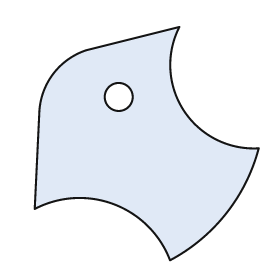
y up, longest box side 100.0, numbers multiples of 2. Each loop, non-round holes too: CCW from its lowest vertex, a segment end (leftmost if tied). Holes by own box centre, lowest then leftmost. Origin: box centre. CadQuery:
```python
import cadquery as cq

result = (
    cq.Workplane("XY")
    .moveTo(10.0, -50.0)
    .threePointArc((34.0, -30.0), (48.0, -2.0))
    .threePointArc((16.0, 14.0), (14.0, 50.0))
    .lineTo(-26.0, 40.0)
    .threePointArc((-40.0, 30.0), (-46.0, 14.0))
    .lineTo(-48.0, -28.0)
    .threePointArc((-14.0, -26.0), (10.0, -50.0))
    .close()
    .moveTo(-12.0, 20.0)
    .circle(6.0)
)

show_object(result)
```